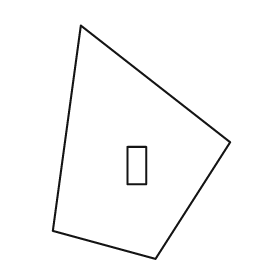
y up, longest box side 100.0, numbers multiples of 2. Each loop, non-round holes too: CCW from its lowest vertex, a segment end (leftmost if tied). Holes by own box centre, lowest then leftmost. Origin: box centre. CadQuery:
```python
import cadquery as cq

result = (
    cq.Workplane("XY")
    .moveTo(6.0, -50.0)
    .lineTo(38.0, 0.0)
    .lineTo(-26.0, 50.0)
    .lineTo(-38.0, -38.0)
    .close()
    .moveTo(-6.0, -18.0)
    .lineTo(2.0, -18.0)
    .lineTo(2.0, -2.0)
    .lineTo(-6.0, -2.0)
    .close()
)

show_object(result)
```